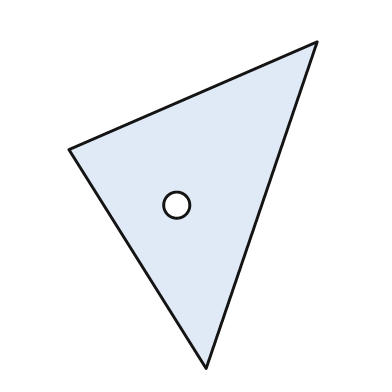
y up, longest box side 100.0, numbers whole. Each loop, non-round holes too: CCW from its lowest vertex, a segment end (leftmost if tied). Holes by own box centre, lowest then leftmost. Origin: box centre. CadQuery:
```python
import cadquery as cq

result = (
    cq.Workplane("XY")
    .moveTo(4.0, -50.0)
    .lineTo(38.0, 50.0)
    .lineTo(-38.0, 17.0)
    .close()
    .moveTo(-5.0, 0.0)
    .circle(4.0)
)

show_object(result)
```